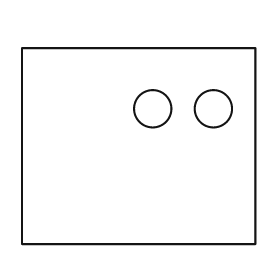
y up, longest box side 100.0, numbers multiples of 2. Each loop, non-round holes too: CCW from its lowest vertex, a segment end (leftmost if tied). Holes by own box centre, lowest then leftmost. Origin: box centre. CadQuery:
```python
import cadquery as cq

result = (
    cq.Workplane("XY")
    .moveTo(-50.0, -42.0)
    .lineTo(50.0, -42.0)
    .lineTo(50.0, 42.0)
    .lineTo(-50.0, 42.0)
    .close()
    .moveTo(6.0, 16.0)
    .circle(8.0)
    .moveTo(32.0, 16.0)
    .circle(8.0)
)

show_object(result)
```